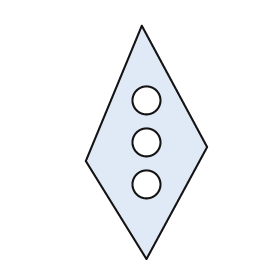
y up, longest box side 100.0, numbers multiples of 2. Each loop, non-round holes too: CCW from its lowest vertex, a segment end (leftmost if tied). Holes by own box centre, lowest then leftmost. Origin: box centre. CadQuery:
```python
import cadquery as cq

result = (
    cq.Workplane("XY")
    .moveTo(0.0, -50.0)
    .lineTo(26.0, -2.0)
    .lineTo(-2.0, 50.0)
    .lineTo(-26.0, -8.0)
    .close()
    .moveTo(0.0, -18.0)
    .circle(6.0)
    .moveTo(0.0, 0.0)
    .circle(6.0)
    .moveTo(0.0, 18.0)
    .circle(6.0)
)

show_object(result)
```